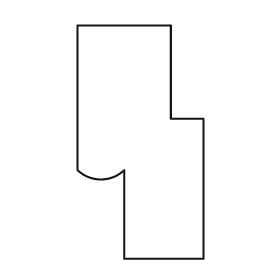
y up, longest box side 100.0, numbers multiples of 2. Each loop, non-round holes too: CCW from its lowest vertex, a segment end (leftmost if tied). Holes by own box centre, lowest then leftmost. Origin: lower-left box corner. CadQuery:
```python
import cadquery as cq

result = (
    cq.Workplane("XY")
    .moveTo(20.0, 0.0)
    .lineTo(54.0, 0.0)
    .lineTo(54.0, 60.0)
    .lineTo(40.0, 60.0)
    .lineTo(40.0, 100.0)
    .lineTo(0.0, 100.0)
    .lineTo(0.0, 38.0)
    .threePointArc((10.0, 34.0), (20.0, 38.0))
    .close()
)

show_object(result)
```